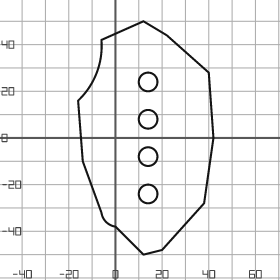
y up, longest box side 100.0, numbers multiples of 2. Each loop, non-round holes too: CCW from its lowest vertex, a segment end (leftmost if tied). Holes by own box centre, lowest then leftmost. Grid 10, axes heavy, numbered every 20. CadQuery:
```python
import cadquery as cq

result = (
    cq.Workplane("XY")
    .moveTo(12.0, -50.0)
    .lineTo(20.0, -48.0)
    .lineTo(38.0, -28.0)
    .lineTo(42.0, 0.0)
    .lineTo(40.0, 28.0)
    .lineTo(22.0, 44.0)
    .lineTo(12.0, 50.0)
    .lineTo(-6.0, 42.0)
    .threePointArc((-8.0, 28.0), (-16.0, 16.0))
    .lineTo(-14.0, -10.0)
    .lineTo(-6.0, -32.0)
    .threePointArc((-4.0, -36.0), (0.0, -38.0))
    .close()
    .moveTo(14.0, -24.0)
    .circle(4.0)
    .moveTo(14.0, -8.0)
    .circle(4.0)
    .moveTo(14.0, 8.0)
    .circle(4.0)
    .moveTo(14.0, 24.0)
    .circle(4.0)
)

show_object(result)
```